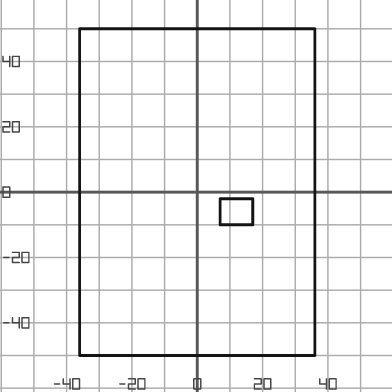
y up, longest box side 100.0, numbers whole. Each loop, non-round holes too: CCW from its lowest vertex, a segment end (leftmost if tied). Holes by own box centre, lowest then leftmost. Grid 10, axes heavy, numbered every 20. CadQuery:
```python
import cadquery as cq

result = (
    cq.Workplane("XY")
    .moveTo(-36.0, -50.0)
    .lineTo(36.0, -50.0)
    .lineTo(36.0, 50.0)
    .lineTo(-36.0, 50.0)
    .close()
    .moveTo(7.0, -10.0)
    .lineTo(17.0, -10.0)
    .lineTo(17.0, -2.0)
    .lineTo(7.0, -2.0)
    .close()
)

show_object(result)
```